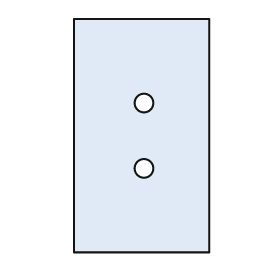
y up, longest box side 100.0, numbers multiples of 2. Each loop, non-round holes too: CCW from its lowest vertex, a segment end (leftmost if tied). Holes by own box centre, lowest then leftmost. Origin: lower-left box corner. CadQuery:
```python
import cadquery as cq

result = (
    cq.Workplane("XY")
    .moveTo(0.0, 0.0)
    .lineTo(58.0, 0.0)
    .lineTo(58.0, 100.0)
    .lineTo(0.0, 100.0)
    .close()
    .moveTo(30.0, 36.0)
    .circle(4.0)
    .moveTo(30.0, 64.0)
    .circle(4.0)
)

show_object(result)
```